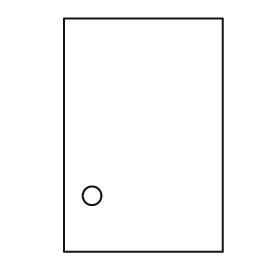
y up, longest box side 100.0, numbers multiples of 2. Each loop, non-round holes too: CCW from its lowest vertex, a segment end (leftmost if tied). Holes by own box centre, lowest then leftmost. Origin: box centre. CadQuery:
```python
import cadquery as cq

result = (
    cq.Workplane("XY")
    .moveTo(-34.0, -50.0)
    .lineTo(34.0, -50.0)
    .lineTo(34.0, 50.0)
    .lineTo(-34.0, 50.0)
    .close()
    .moveTo(-22.0, -26.0)
    .circle(4.0)
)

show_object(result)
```